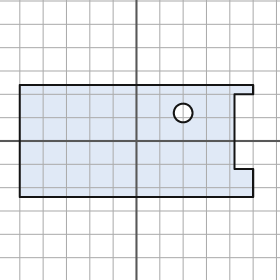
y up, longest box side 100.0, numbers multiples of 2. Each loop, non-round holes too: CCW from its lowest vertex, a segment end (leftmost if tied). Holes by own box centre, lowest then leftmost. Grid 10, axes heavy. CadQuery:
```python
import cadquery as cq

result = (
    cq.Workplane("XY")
    .moveTo(-50.0, -24.0)
    .lineTo(50.0, -24.0)
    .lineTo(50.0, -12.0)
    .lineTo(42.0, -12.0)
    .lineTo(42.0, 20.0)
    .lineTo(50.0, 20.0)
    .lineTo(50.0, 24.0)
    .lineTo(-50.0, 24.0)
    .close()
    .moveTo(20.0, 12.0)
    .circle(4.0)
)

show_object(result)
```